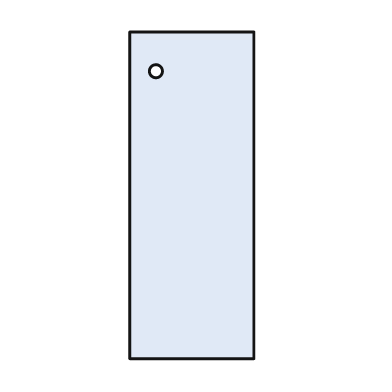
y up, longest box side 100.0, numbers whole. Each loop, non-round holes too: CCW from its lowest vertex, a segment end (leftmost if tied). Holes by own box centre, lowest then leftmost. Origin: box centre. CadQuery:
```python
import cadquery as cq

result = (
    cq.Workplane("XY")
    .moveTo(-19.0, -50.0)
    .lineTo(19.0, -50.0)
    .lineTo(19.0, 50.0)
    .lineTo(-19.0, 50.0)
    .close()
    .moveTo(-11.0, 38.0)
    .circle(2.0)
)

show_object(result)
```